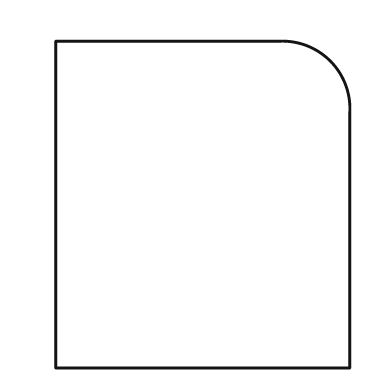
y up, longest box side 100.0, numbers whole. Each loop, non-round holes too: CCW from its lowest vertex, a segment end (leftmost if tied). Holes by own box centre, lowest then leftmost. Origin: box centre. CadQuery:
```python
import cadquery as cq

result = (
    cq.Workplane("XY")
    .moveTo(-45.0, -50.0)
    .lineTo(45.0, -50.0)
    .lineTo(45.0, 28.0)
    .threePointArc((39.0, 44.0), (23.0, 50.0))
    .lineTo(-45.0, 50.0)
    .close()
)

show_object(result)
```